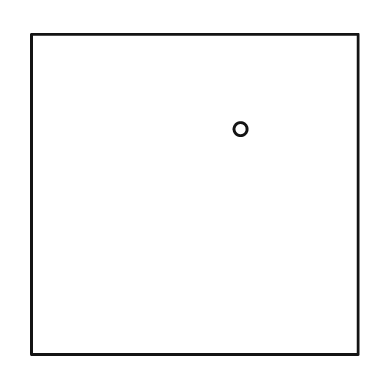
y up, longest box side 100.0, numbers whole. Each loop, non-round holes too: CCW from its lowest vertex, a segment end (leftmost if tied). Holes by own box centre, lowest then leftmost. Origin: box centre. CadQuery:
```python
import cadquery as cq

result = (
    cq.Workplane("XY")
    .moveTo(-50.0, -49.0)
    .lineTo(50.0, -49.0)
    .lineTo(50.0, 49.0)
    .lineTo(-50.0, 49.0)
    .close()
    .moveTo(14.0, 20.0)
    .circle(2.0)
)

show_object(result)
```